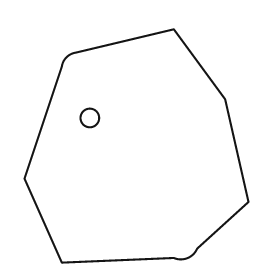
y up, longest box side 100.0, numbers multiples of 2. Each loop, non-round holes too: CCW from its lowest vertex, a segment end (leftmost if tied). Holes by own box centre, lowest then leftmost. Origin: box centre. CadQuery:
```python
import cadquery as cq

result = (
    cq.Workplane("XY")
    .moveTo(-32.0, -50.0)
    .lineTo(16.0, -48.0)
    .threePointArc((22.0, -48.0), (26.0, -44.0))
    .lineTo(48.0, -24.0)
    .lineTo(38.0, 20.0)
    .lineTo(16.0, 50.0)
    .lineTo(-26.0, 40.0)
    .threePointArc((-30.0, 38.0), (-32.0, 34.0))
    .lineTo(-48.0, -14.0)
    .close()
    .moveTo(-20.0, 12.0)
    .circle(4.0)
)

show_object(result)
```